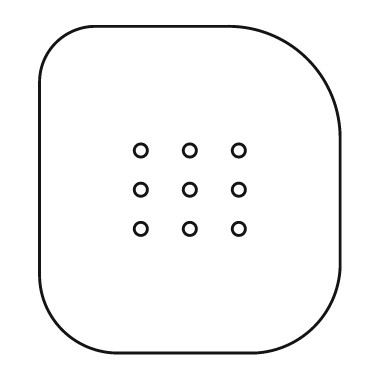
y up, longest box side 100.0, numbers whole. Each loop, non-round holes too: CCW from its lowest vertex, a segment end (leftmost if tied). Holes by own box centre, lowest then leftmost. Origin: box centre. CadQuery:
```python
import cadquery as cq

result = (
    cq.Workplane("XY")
    .moveTo(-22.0, -50.0)
    .lineTo(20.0, -50.0)
    .threePointArc((38.0, -42.0), (46.0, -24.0))
    .lineTo(46.0, 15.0)
    .threePointArc((36.0, 40.0), (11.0, 50.0))
    .lineTo(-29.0, 50.0)
    .threePointArc((-41.0, 45.0), (-46.0, 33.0))
    .lineTo(-46.0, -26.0)
    .threePointArc((-39.0, -43.0), (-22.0, -50.0))
    .close()
    .moveTo(-15.0, -12.0)
    .circle(2.0)
    .moveTo(0.0, -12.0)
    .circle(2.0)
    .moveTo(15.0, -12.0)
    .circle(2.0)
    .moveTo(-15.0, 0.0)
    .circle(2.0)
    .moveTo(0.0, 0.0)
    .circle(2.0)
    .moveTo(15.0, 0.0)
    .circle(2.0)
    .moveTo(-15.0, 12.0)
    .circle(2.0)
    .moveTo(0.0, 12.0)
    .circle(2.0)
    .moveTo(15.0, 12.0)
    .circle(2.0)
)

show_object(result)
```